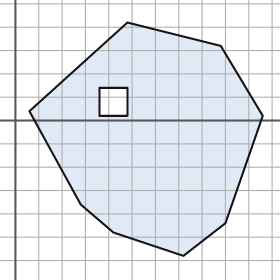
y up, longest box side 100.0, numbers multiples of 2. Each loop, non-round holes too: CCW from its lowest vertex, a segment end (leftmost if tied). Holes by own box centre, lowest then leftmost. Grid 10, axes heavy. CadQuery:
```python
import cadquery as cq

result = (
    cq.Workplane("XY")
    .moveTo(72.0, -58.0)
    .lineTo(90.0, -44.0)
    .lineTo(106.0, 2.0)
    .lineTo(88.0, 32.0)
    .lineTo(48.0, 42.0)
    .lineTo(6.0, 4.0)
    .lineTo(28.0, -36.0)
    .lineTo(42.0, -48.0)
    .close()
    .moveTo(36.0, 2.0)
    .lineTo(48.0, 2.0)
    .lineTo(48.0, 14.0)
    .lineTo(36.0, 14.0)
    .close()
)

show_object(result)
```